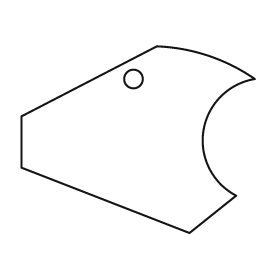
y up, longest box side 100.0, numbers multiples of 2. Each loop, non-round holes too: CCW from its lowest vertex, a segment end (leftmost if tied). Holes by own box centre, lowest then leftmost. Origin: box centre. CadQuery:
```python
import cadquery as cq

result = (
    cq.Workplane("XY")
    .moveTo(22.0, -40.0)
    .lineTo(42.0, -24.0)
    .threePointArc((28.0, 4.0), (50.0, 26.0))
    .threePointArc((30.0, 36.0), (8.0, 40.0))
    .lineTo(-50.0, 10.0)
    .lineTo(-50.0, -12.0)
    .close()
    .moveTo(-2.0, 26.0)
    .circle(4.0)
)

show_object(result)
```